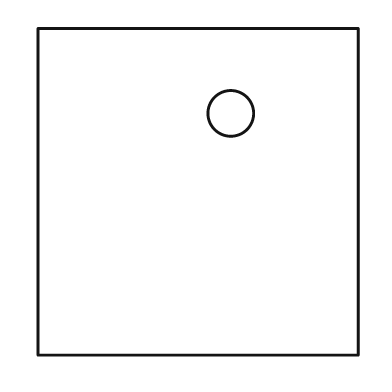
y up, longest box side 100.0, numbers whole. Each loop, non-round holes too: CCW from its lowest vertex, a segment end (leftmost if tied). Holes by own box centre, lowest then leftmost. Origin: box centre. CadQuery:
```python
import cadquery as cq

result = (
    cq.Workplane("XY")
    .moveTo(-49.0, -50.0)
    .lineTo(49.0, -50.0)
    .lineTo(49.0, 50.0)
    .lineTo(-49.0, 50.0)
    .close()
    .moveTo(10.0, 24.0)
    .circle(7.0)
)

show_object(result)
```